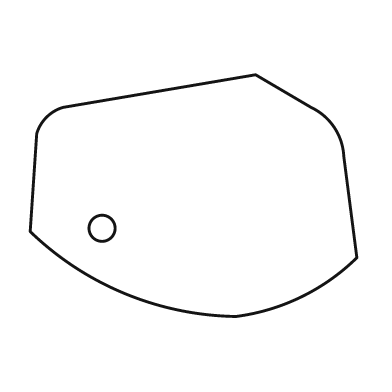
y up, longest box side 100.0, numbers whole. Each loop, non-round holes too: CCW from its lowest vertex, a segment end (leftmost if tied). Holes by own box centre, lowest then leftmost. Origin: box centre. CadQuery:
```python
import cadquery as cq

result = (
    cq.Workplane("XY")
    .moveTo(13.0, -37.0)
    .threePointArc((33.0, -31.0), (50.0, -19.0))
    .lineTo(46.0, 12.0)
    .threePointArc((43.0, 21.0), (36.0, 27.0))
    .lineTo(19.0, 37.0)
    .lineTo(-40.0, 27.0)
    .threePointArc((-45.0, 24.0), (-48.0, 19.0))
    .lineTo(-50.0, -11.0)
    .threePointArc((-21.0, -30.0), (13.0, -37.0))
    .close()
    .moveTo(-28.0, -10.0)
    .circle(4.0)
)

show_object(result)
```